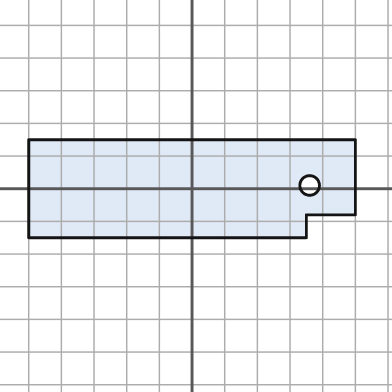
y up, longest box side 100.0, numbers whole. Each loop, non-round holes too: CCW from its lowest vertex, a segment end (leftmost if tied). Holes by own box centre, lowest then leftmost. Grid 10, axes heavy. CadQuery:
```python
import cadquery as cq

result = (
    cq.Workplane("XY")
    .moveTo(-50.0, -15.0)
    .lineTo(35.0, -15.0)
    .lineTo(35.0, -8.0)
    .lineTo(50.0, -8.0)
    .lineTo(50.0, 15.0)
    .lineTo(-50.0, 15.0)
    .close()
    .moveTo(36.0, 1.0)
    .circle(3.0)
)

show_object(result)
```